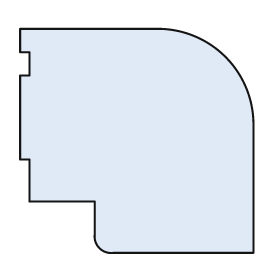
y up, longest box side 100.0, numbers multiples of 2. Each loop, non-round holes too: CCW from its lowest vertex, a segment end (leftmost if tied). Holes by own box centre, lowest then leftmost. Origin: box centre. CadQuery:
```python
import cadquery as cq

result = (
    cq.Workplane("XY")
    .moveTo(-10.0, -48.0)
    .lineTo(50.0, -48.0)
    .lineTo(50.0, 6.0)
    .threePointArc((38.0, 36.0), (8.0, 48.0))
    .lineTo(-50.0, 48.0)
    .lineTo(-50.0, 38.0)
    .lineTo(-46.0, 38.0)
    .lineTo(-46.0, 28.0)
    .lineTo(-50.0, 28.0)
    .lineTo(-50.0, -8.0)
    .lineTo(-46.0, -8.0)
    .lineTo(-46.0, -26.0)
    .lineTo(-18.0, -26.0)
    .lineTo(-18.0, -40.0)
    .threePointArc((-16.0, -46.0), (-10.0, -48.0))
    .close()
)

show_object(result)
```